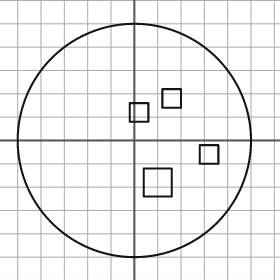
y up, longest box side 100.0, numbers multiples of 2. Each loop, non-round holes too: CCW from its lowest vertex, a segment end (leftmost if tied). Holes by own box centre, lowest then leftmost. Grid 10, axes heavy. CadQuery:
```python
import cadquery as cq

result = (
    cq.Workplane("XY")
    .moveTo(0.0, 0.0)
    .circle(50.0)
    .moveTo(4.0, -24.0)
    .lineTo(16.0, -24.0)
    .lineTo(16.0, -12.0)
    .lineTo(4.0, -12.0)
    .close()
    .moveTo(28.0, -10.0)
    .lineTo(36.0, -10.0)
    .lineTo(36.0, -2.0)
    .lineTo(28.0, -2.0)
    .close()
    .moveTo(-2.0, 8.0)
    .lineTo(6.0, 8.0)
    .lineTo(6.0, 16.0)
    .lineTo(-2.0, 16.0)
    .close()
    .moveTo(12.0, 14.0)
    .lineTo(20.0, 14.0)
    .lineTo(20.0, 22.0)
    .lineTo(12.0, 22.0)
    .close()
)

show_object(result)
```